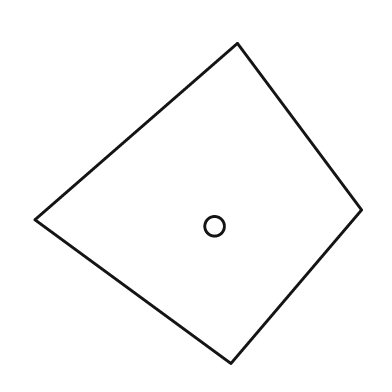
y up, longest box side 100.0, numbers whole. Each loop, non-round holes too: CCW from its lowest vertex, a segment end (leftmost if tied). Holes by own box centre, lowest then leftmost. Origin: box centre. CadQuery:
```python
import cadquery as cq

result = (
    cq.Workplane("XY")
    .moveTo(10.0, -49.0)
    .lineTo(50.0, -2.0)
    .lineTo(12.0, 49.0)
    .lineTo(-50.0, -5.0)
    .close()
    .moveTo(5.0, -7.0)
    .circle(3.0)
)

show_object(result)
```